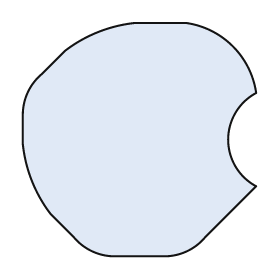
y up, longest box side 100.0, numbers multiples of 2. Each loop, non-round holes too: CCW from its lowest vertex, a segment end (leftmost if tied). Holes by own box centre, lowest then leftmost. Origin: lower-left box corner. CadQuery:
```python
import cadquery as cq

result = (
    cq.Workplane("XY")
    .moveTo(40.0, 0.0)
    .lineTo(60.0, 0.0)
    .threePointArc((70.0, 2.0), (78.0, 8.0))
    .lineTo(100.0, 30.0)
    .threePointArc((88.0, 50.0), (100.0, 70.0))
    .threePointArc((90.0, 90.0), (70.0, 100.0))
    .lineTo(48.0, 100.0)
    .threePointArc((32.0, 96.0), (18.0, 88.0))
    .lineTo(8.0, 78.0)
    .threePointArc((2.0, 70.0), (0.0, 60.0))
    .lineTo(0.0, 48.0)
    .threePointArc((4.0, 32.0), (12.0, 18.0))
    .lineTo(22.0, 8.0)
    .threePointArc((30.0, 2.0), (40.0, 0.0))
    .close()
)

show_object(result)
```